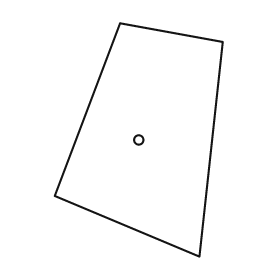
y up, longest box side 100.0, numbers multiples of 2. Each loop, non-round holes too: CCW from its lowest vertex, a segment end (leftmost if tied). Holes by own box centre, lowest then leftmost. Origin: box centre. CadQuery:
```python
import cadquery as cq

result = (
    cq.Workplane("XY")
    .moveTo(26.0, -50.0)
    .lineTo(36.0, 42.0)
    .lineTo(-8.0, 50.0)
    .lineTo(-36.0, -24.0)
    .close()
    .moveTo(0.0, 0.0)
    .circle(2.0)
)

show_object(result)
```